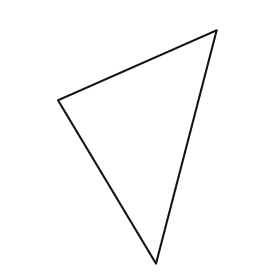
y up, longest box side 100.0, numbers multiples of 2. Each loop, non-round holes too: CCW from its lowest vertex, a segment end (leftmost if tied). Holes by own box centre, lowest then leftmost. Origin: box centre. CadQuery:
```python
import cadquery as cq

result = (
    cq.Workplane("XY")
    .moveTo(8.0, -50.0)
    .lineTo(34.0, 50.0)
    .lineTo(-34.0, 20.0)
    .close()
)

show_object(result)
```